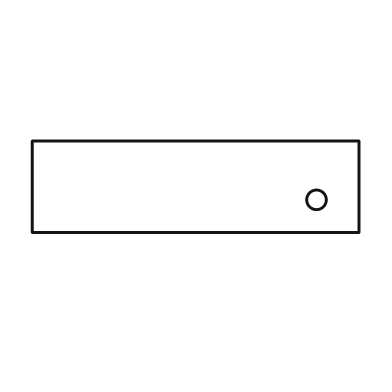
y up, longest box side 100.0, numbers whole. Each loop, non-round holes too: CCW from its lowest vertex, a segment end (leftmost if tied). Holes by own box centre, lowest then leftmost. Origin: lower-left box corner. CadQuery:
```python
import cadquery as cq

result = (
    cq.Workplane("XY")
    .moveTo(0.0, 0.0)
    .lineTo(100.0, 0.0)
    .lineTo(100.0, 28.0)
    .lineTo(0.0, 28.0)
    .close()
    .moveTo(87.0, 10.0)
    .circle(3.0)
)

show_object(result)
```